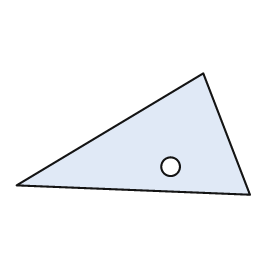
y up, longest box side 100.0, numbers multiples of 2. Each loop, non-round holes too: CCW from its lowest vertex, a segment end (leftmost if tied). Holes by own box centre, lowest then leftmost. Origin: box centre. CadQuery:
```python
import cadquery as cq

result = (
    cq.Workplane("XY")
    .moveTo(50.0, -26.0)
    .lineTo(30.0, 26.0)
    .lineTo(-50.0, -22.0)
    .close()
    .moveTo(16.0, -14.0)
    .circle(4.0)
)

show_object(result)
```